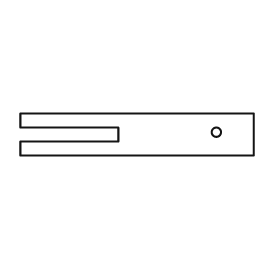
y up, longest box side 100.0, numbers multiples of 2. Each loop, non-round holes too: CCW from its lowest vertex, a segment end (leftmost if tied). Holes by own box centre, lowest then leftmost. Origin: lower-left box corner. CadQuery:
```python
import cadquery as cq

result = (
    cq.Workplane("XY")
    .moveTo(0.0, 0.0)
    .lineTo(100.0, 0.0)
    .lineTo(100.0, 18.0)
    .lineTo(0.0, 18.0)
    .lineTo(0.0, 12.0)
    .lineTo(42.0, 12.0)
    .lineTo(42.0, 6.0)
    .lineTo(0.0, 6.0)
    .close()
    .moveTo(84.0, 10.0)
    .circle(2.0)
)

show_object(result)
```